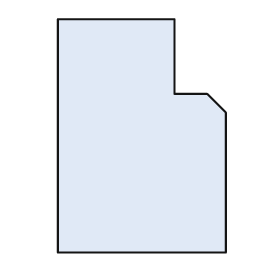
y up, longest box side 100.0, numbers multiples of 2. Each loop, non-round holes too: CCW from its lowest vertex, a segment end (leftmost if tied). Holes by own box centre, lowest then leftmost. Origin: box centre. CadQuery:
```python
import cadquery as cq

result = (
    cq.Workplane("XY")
    .moveTo(-36.0, -50.0)
    .lineTo(36.0, -50.0)
    .lineTo(36.0, 10.0)
    .lineTo(28.0, 18.0)
    .lineTo(14.0, 18.0)
    .lineTo(14.0, 50.0)
    .lineTo(-36.0, 50.0)
    .close()
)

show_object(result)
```